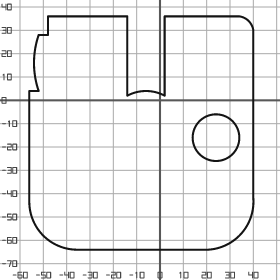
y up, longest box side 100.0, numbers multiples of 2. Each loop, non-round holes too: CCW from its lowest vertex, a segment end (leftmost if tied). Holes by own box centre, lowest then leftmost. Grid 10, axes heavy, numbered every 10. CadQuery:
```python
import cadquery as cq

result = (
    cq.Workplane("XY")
    .moveTo(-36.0, -64.0)
    .lineTo(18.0, -64.0)
    .threePointArc((34.0, -58.0), (40.0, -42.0))
    .lineTo(40.0, 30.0)
    .threePointArc((38.0, 34.0), (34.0, 36.0))
    .lineTo(2.0, 36.0)
    .lineTo(2.0, 2.0)
    .threePointArc((-6.0, 4.0), (-14.0, 2.0))
    .lineTo(-14.0, 36.0)
    .lineTo(-48.0, 36.0)
    .lineTo(-48.0, 28.0)
    .lineTo(-52.0, 28.0)
    .threePointArc((-54.0, 16.0), (-52.0, 4.0))
    .lineTo(-56.0, 4.0)
    .lineTo(-56.0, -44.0)
    .threePointArc((-50.0, -58.0), (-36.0, -64.0))
    .close()
    .moveTo(24.0, -16.0)
    .circle(10.0)
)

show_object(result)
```